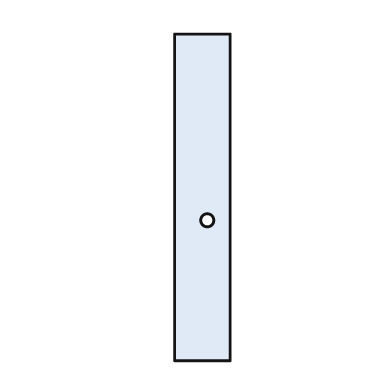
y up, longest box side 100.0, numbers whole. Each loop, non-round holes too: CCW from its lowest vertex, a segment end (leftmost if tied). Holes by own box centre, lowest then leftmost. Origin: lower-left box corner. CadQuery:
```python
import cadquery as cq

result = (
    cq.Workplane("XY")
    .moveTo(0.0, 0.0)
    .lineTo(17.0, 0.0)
    .lineTo(17.0, 100.0)
    .lineTo(0.0, 100.0)
    .close()
    .moveTo(10.0, 43.0)
    .circle(2.0)
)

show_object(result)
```